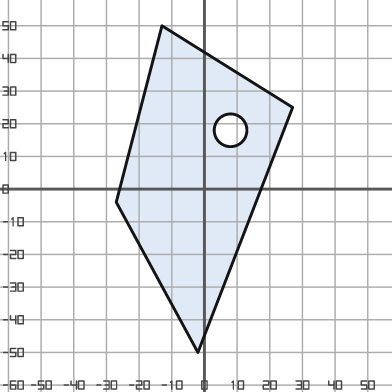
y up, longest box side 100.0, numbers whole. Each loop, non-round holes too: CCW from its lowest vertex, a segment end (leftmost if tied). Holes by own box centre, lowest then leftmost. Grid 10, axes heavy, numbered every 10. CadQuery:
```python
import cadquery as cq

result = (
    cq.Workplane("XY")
    .moveTo(-2.0, -50.0)
    .lineTo(27.0, 25.0)
    .lineTo(-13.0, 50.0)
    .lineTo(-27.0, -4.0)
    .close()
    .moveTo(8.0, 18.0)
    .circle(5.0)
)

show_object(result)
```